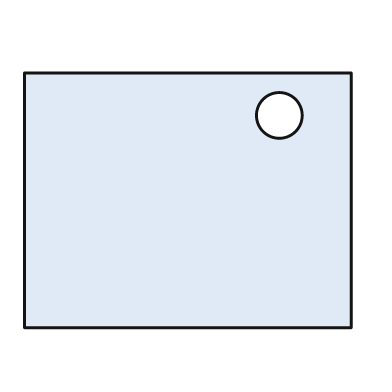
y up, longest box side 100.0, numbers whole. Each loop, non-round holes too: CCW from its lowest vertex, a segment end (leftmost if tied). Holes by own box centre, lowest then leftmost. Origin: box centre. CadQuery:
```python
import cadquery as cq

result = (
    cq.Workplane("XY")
    .moveTo(-50.0, -39.0)
    .lineTo(50.0, -39.0)
    .lineTo(50.0, 39.0)
    .lineTo(-50.0, 39.0)
    .close()
    .moveTo(28.0, 26.0)
    .circle(7.0)
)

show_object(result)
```